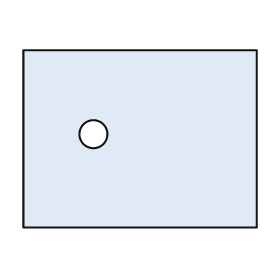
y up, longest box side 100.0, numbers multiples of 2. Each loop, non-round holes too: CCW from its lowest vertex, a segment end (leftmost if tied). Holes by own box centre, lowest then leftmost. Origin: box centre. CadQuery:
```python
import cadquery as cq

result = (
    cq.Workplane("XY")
    .moveTo(-50.0, -38.0)
    .lineTo(50.0, -38.0)
    .lineTo(50.0, 38.0)
    .lineTo(-50.0, 38.0)
    .close()
    .moveTo(-20.0, 2.0)
    .circle(6.0)
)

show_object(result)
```